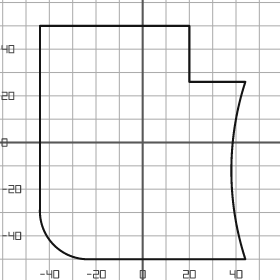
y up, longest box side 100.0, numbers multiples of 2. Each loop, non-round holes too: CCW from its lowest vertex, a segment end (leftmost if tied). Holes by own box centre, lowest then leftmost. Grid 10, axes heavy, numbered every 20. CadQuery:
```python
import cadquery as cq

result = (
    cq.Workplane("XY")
    .moveTo(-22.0, -50.0)
    .lineTo(44.0, -50.0)
    .threePointArc((38.0, -12.0), (44.0, 26.0))
    .lineTo(20.0, 26.0)
    .lineTo(20.0, 50.0)
    .lineTo(-44.0, 50.0)
    .lineTo(-44.0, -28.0)
    .threePointArc((-38.0, -44.0), (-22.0, -50.0))
    .close()
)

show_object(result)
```